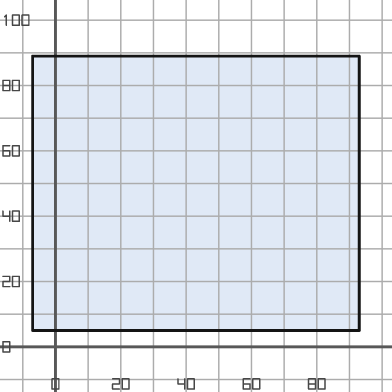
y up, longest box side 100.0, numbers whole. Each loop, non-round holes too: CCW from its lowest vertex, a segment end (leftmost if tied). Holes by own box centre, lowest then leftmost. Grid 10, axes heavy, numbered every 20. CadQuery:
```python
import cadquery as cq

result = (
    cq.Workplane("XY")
    .moveTo(-7.0, 5.0)
    .lineTo(93.0, 5.0)
    .lineTo(93.0, 89.0)
    .lineTo(-7.0, 89.0)
    .close()
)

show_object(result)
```